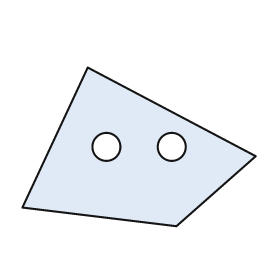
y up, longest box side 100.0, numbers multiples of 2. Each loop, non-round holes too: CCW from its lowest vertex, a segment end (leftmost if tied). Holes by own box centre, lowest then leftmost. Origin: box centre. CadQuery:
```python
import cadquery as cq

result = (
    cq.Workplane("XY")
    .moveTo(16.0, -34.0)
    .lineTo(50.0, -4.0)
    .lineTo(-22.0, 34.0)
    .lineTo(-50.0, -26.0)
    .close()
    .moveTo(-14.0, 0.0)
    .circle(6.0)
    .moveTo(14.0, 0.0)
    .circle(6.0)
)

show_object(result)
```